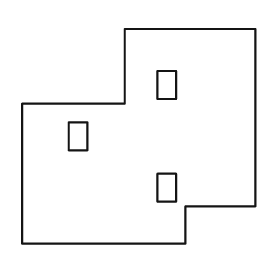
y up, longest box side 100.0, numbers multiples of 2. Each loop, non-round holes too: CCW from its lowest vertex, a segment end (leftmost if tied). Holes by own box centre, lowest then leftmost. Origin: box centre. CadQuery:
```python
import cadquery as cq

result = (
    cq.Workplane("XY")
    .moveTo(-50.0, -46.0)
    .lineTo(20.0, -46.0)
    .lineTo(20.0, -30.0)
    .lineTo(50.0, -30.0)
    .lineTo(50.0, 46.0)
    .lineTo(-6.0, 46.0)
    .lineTo(-6.0, 14.0)
    .lineTo(-50.0, 14.0)
    .close()
    .moveTo(8.0, -28.0)
    .lineTo(16.0, -28.0)
    .lineTo(16.0, -16.0)
    .lineTo(8.0, -16.0)
    .close()
    .moveTo(-30.0, -6.0)
    .lineTo(-22.0, -6.0)
    .lineTo(-22.0, 6.0)
    .lineTo(-30.0, 6.0)
    .close()
    .moveTo(8.0, 16.0)
    .lineTo(16.0, 16.0)
    .lineTo(16.0, 28.0)
    .lineTo(8.0, 28.0)
    .close()
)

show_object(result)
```